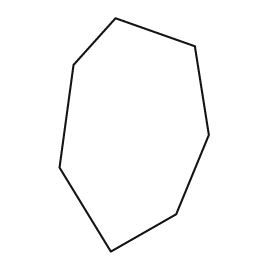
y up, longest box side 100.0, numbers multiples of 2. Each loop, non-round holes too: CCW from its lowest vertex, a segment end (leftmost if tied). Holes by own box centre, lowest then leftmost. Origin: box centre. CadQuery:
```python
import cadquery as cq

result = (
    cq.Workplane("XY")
    .moveTo(-10.0, -50.0)
    .lineTo(18.0, -34.0)
    .lineTo(32.0, 0.0)
    .lineTo(26.0, 38.0)
    .lineTo(-8.0, 50.0)
    .lineTo(-26.0, 30.0)
    .lineTo(-32.0, -14.0)
    .close()
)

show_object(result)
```